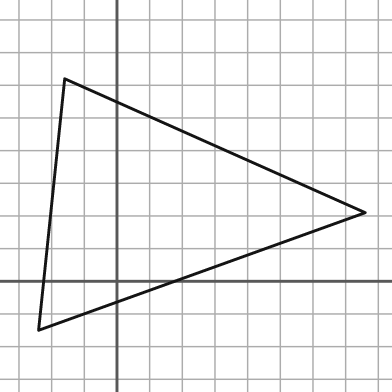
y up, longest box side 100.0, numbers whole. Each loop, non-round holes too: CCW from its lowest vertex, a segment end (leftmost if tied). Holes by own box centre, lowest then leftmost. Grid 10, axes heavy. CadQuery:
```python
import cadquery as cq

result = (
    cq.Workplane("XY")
    .moveTo(-24.0, -15.0)
    .lineTo(76.0, 21.0)
    .lineTo(-16.0, 62.0)
    .close()
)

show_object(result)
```